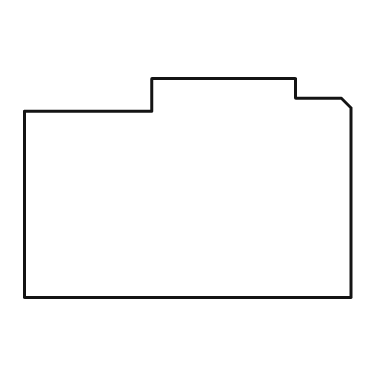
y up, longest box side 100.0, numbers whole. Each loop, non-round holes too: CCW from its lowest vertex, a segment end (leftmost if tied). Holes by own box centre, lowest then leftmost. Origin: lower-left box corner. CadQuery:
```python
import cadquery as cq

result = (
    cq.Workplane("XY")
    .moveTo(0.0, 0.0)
    .lineTo(100.0, 0.0)
    .lineTo(100.0, 58.0)
    .lineTo(97.0, 61.0)
    .lineTo(83.0, 61.0)
    .lineTo(83.0, 67.0)
    .lineTo(39.0, 67.0)
    .lineTo(39.0, 57.0)
    .lineTo(0.0, 57.0)
    .close()
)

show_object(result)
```